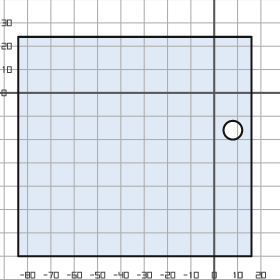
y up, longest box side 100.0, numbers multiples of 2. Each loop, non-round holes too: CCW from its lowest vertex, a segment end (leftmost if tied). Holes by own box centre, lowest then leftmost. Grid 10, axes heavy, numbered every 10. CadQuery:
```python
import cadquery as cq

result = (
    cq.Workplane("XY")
    .moveTo(-84.0, -70.0)
    .lineTo(16.0, -70.0)
    .lineTo(16.0, 24.0)
    .lineTo(-84.0, 24.0)
    .close()
    .moveTo(8.0, -16.0)
    .circle(4.0)
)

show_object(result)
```